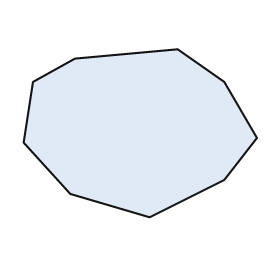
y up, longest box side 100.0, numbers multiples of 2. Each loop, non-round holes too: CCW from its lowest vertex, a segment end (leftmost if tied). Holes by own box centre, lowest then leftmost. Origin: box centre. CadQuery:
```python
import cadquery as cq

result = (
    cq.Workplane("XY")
    .moveTo(4.0, -36.0)
    .lineTo(36.0, -20.0)
    .lineTo(50.0, -2.0)
    .lineTo(36.0, 22.0)
    .lineTo(16.0, 36.0)
    .lineTo(-28.0, 32.0)
    .lineTo(-46.0, 22.0)
    .lineTo(-50.0, -4.0)
    .lineTo(-30.0, -26.0)
    .close()
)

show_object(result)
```